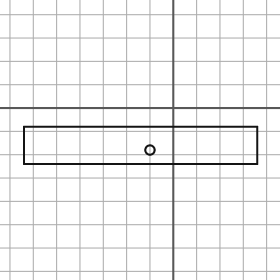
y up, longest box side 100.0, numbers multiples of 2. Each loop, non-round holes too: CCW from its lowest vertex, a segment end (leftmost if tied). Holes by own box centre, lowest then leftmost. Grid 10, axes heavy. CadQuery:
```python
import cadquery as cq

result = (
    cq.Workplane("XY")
    .moveTo(-64.0, -24.0)
    .lineTo(36.0, -24.0)
    .lineTo(36.0, -8.0)
    .lineTo(-64.0, -8.0)
    .close()
    .moveTo(-10.0, -18.0)
    .circle(2.0)
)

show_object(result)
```